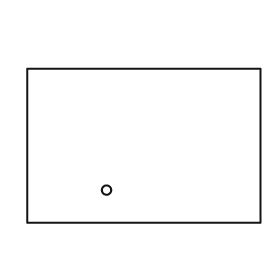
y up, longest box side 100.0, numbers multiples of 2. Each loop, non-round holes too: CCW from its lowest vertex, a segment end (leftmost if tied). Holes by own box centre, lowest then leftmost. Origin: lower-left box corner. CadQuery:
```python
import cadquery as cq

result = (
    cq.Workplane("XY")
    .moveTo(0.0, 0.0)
    .lineTo(100.0, 0.0)
    .lineTo(100.0, 66.0)
    .lineTo(0.0, 66.0)
    .close()
    .moveTo(34.0, 14.0)
    .circle(2.0)
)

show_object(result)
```